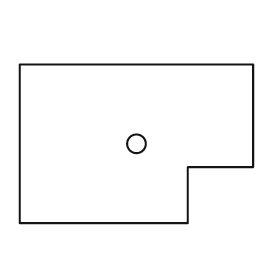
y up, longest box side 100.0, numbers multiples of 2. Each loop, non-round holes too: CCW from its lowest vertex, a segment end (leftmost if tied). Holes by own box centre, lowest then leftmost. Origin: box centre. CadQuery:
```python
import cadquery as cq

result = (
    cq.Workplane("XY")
    .moveTo(-50.0, -34.0)
    .lineTo(22.0, -34.0)
    .lineTo(22.0, -10.0)
    .lineTo(50.0, -10.0)
    .lineTo(50.0, 34.0)
    .lineTo(-50.0, 34.0)
    .close()
    .moveTo(0.0, 0.0)
    .circle(4.0)
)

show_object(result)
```